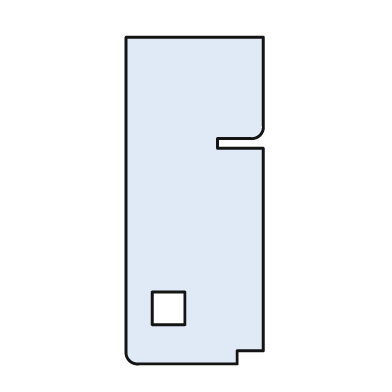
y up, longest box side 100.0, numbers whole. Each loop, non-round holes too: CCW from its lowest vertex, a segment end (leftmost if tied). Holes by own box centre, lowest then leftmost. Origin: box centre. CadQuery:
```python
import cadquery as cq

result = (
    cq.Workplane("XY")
    .moveTo(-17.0, -50.0)
    .lineTo(13.0, -50.0)
    .lineTo(13.0, -46.0)
    .lineTo(21.0, -46.0)
    .lineTo(21.0, 16.0)
    .lineTo(7.0, 16.0)
    .lineTo(7.0, 19.0)
    .lineTo(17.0, 19.0)
    .threePointArc((20.0, 20.0), (21.0, 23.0))
    .lineTo(21.0, 50.0)
    .lineTo(-21.0, 50.0)
    .lineTo(-21.0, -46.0)
    .threePointArc((-20.0, -49.0), (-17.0, -50.0))
    .close()
    .moveTo(-13.0, -38.0)
    .lineTo(-3.0, -38.0)
    .lineTo(-3.0, -28.0)
    .lineTo(-13.0, -28.0)
    .close()
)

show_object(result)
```